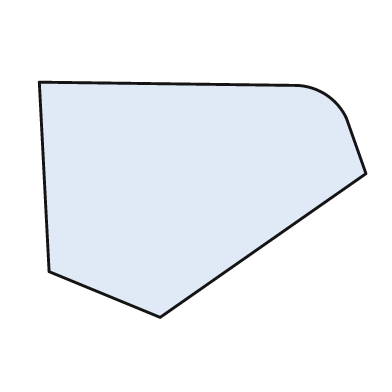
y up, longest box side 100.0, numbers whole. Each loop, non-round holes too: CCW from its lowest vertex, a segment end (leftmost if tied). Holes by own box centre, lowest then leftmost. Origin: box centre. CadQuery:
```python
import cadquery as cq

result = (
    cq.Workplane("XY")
    .moveTo(-13.0, -36.0)
    .lineTo(50.0, 8.0)
    .lineTo(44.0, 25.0)
    .threePointArc((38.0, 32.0), (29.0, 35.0))
    .lineTo(-50.0, 36.0)
    .lineTo(-47.0, -22.0)
    .close()
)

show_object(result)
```